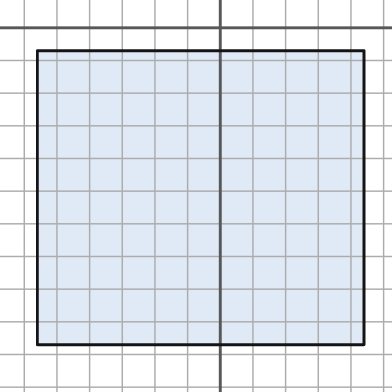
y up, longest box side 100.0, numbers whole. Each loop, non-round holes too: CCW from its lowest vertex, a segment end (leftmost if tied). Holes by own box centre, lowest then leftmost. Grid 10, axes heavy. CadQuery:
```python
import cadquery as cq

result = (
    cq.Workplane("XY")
    .moveTo(-56.0, -97.0)
    .lineTo(44.0, -97.0)
    .lineTo(44.0, -7.0)
    .lineTo(-56.0, -7.0)
    .close()
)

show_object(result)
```